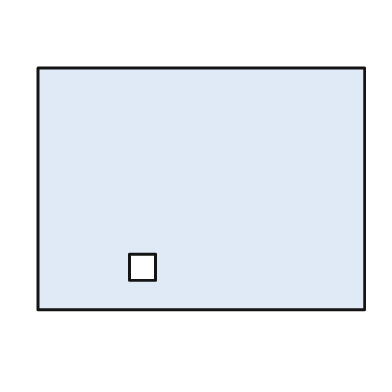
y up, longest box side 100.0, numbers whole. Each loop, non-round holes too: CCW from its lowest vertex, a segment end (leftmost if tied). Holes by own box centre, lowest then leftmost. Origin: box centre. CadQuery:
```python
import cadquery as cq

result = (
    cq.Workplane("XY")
    .moveTo(-50.0, -37.0)
    .lineTo(50.0, -37.0)
    .lineTo(50.0, 37.0)
    .lineTo(-50.0, 37.0)
    .close()
    .moveTo(-22.0, -28.0)
    .lineTo(-14.0, -28.0)
    .lineTo(-14.0, -20.0)
    .lineTo(-22.0, -20.0)
    .close()
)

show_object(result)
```